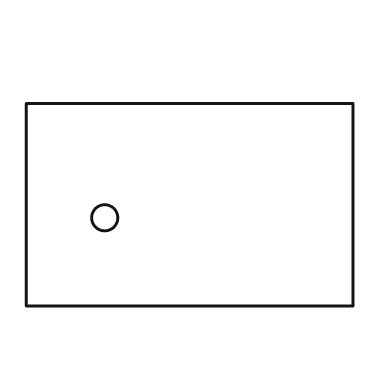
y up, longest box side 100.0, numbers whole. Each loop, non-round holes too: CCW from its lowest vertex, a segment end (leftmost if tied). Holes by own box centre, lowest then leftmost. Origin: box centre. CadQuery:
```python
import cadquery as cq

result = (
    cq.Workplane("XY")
    .moveTo(-50.0, -31.0)
    .lineTo(50.0, -31.0)
    .lineTo(50.0, 31.0)
    .lineTo(-50.0, 31.0)
    .close()
    .moveTo(-26.0, -4.0)
    .circle(4.0)
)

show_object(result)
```